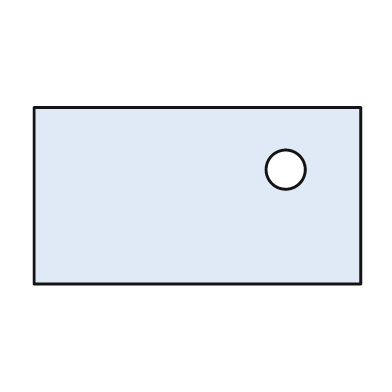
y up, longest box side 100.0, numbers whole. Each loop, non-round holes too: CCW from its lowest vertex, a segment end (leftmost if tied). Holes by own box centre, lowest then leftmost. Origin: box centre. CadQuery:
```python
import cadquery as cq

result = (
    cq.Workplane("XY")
    .moveTo(-50.0, -27.0)
    .lineTo(50.0, -27.0)
    .lineTo(50.0, 27.0)
    .lineTo(-50.0, 27.0)
    .close()
    .moveTo(27.0, 8.0)
    .circle(6.0)
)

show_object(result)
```